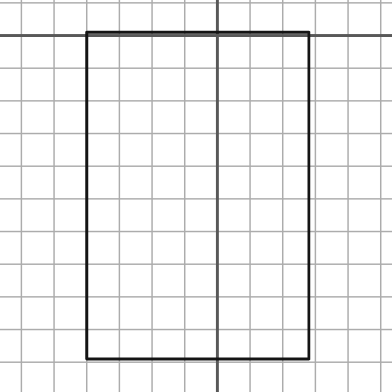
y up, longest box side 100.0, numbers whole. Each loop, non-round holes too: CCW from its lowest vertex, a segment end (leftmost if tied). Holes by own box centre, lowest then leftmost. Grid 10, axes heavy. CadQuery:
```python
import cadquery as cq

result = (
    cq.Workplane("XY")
    .moveTo(-40.0, -99.0)
    .lineTo(28.0, -99.0)
    .lineTo(28.0, 1.0)
    .lineTo(-40.0, 1.0)
    .close()
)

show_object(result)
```